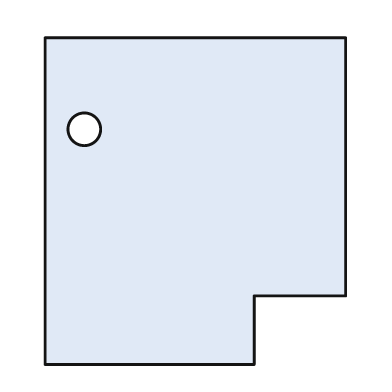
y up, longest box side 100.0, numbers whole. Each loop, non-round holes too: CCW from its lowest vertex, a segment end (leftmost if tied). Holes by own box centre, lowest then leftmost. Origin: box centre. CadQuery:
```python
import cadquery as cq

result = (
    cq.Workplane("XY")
    .moveTo(-46.0, -50.0)
    .lineTo(18.0, -50.0)
    .lineTo(18.0, -29.0)
    .lineTo(46.0, -29.0)
    .lineTo(46.0, 50.0)
    .lineTo(-46.0, 50.0)
    .close()
    .moveTo(-34.0, 22.0)
    .circle(5.0)
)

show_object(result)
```